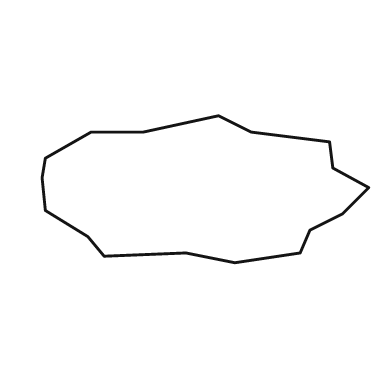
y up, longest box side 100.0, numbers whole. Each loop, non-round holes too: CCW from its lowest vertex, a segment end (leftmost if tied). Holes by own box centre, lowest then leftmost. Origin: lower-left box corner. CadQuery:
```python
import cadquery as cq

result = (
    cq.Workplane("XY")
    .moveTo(59.0, 0.0)
    .lineTo(79.0, 3.0)
    .lineTo(82.0, 10.0)
    .lineTo(92.0, 15.0)
    .lineTo(100.0, 23.0)
    .lineTo(89.0, 29.0)
    .lineTo(88.0, 37.0)
    .lineTo(64.0, 40.0)
    .lineTo(54.0, 45.0)
    .lineTo(31.0, 40.0)
    .lineTo(15.0, 40.0)
    .lineTo(1.0, 32.0)
    .lineTo(0.0, 26.0)
    .lineTo(1.0, 16.0)
    .lineTo(14.0, 8.0)
    .lineTo(19.0, 2.0)
    .lineTo(44.0, 3.0)
    .close()
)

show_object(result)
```